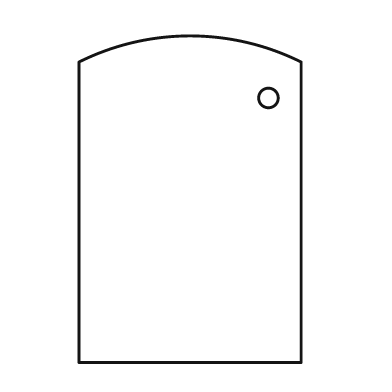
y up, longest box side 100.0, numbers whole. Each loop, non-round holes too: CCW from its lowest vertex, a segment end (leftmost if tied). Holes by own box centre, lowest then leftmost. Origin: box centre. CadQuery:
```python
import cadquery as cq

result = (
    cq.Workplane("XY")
    .moveTo(-34.0, -50.0)
    .lineTo(34.0, -50.0)
    .lineTo(34.0, 42.0)
    .threePointArc((0.0, 50.0), (-34.0, 42.0))
    .close()
    .moveTo(24.0, 31.0)
    .circle(3.0)
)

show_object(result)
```